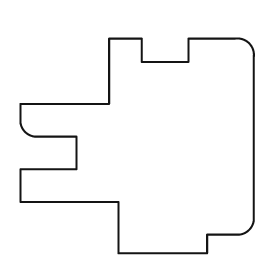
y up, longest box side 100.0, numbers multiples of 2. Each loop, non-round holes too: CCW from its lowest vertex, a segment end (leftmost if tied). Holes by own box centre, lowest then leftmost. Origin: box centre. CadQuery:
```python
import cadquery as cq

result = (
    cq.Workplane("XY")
    .moveTo(-8.0, -46.0)
    .lineTo(30.0, -46.0)
    .lineTo(30.0, -38.0)
    .lineTo(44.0, -38.0)
    .threePointArc((48.0, -36.0), (50.0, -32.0))
    .lineTo(50.0, 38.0)
    .threePointArc((48.0, 44.0), (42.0, 46.0))
    .lineTo(22.0, 46.0)
    .lineTo(22.0, 36.0)
    .lineTo(2.0, 36.0)
    .lineTo(2.0, 46.0)
    .lineTo(-12.0, 46.0)
    .lineTo(-12.0, 18.0)
    .lineTo(-50.0, 18.0)
    .lineTo(-50.0, 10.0)
    .threePointArc((-48.0, 6.0), (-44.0, 4.0))
    .lineTo(-26.0, 4.0)
    .lineTo(-26.0, -10.0)
    .lineTo(-50.0, -10.0)
    .lineTo(-50.0, -24.0)
    .lineTo(-8.0, -24.0)
    .close()
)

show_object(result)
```